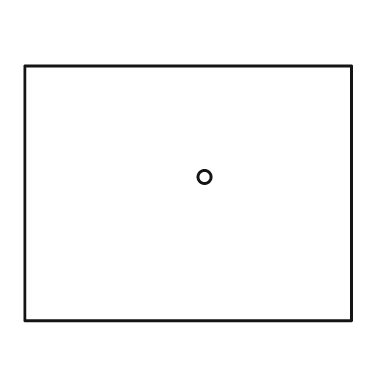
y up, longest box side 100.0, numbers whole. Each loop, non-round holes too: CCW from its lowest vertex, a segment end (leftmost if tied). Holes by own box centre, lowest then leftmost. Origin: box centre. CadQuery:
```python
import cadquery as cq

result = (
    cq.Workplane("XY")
    .moveTo(-50.0, -39.0)
    .lineTo(50.0, -39.0)
    .lineTo(50.0, 39.0)
    .lineTo(-50.0, 39.0)
    .close()
    .moveTo(5.0, 5.0)
    .circle(2.0)
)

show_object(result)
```